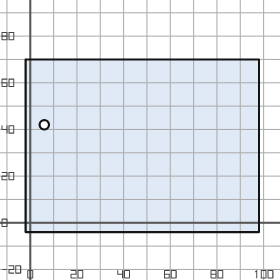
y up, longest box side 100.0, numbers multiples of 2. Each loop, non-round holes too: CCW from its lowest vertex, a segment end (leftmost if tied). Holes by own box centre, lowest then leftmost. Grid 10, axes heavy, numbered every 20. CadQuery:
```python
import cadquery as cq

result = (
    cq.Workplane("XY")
    .moveTo(-2.0, -4.0)
    .lineTo(98.0, -4.0)
    .lineTo(98.0, 70.0)
    .lineTo(-2.0, 70.0)
    .close()
    .moveTo(6.0, 42.0)
    .circle(2.0)
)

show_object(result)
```